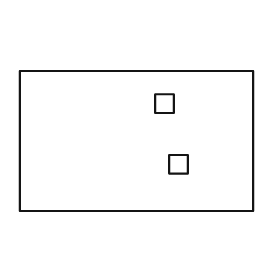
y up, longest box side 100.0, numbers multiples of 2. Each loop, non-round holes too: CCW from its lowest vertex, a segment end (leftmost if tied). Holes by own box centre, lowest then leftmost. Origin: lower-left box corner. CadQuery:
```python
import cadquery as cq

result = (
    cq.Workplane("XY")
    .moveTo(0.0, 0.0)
    .lineTo(100.0, 0.0)
    .lineTo(100.0, 60.0)
    .lineTo(0.0, 60.0)
    .close()
    .moveTo(64.0, 16.0)
    .lineTo(72.0, 16.0)
    .lineTo(72.0, 24.0)
    .lineTo(64.0, 24.0)
    .close()
    .moveTo(58.0, 42.0)
    .lineTo(66.0, 42.0)
    .lineTo(66.0, 50.0)
    .lineTo(58.0, 50.0)
    .close()
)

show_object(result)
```